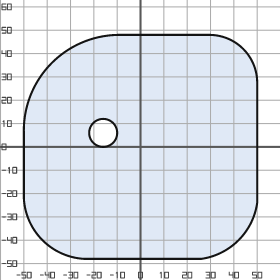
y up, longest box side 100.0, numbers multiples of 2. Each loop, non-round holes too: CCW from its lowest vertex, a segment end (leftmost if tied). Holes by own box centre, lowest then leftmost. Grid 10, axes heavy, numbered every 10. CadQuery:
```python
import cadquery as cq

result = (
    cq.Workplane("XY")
    .moveTo(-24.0, -48.0)
    .lineTo(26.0, -48.0)
    .threePointArc((42.0, -40.0), (50.0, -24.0))
    .lineTo(50.0, 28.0)
    .threePointArc((44.0, 42.0), (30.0, 48.0))
    .lineTo(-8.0, 48.0)
    .threePointArc((-38.0, 36.0), (-50.0, 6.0))
    .lineTo(-50.0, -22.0)
    .threePointArc((-42.0, -40.0), (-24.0, -48.0))
    .close()
    .moveTo(-16.0, 6.0)
    .circle(6.0)
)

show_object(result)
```